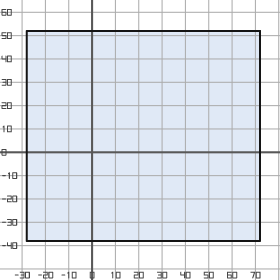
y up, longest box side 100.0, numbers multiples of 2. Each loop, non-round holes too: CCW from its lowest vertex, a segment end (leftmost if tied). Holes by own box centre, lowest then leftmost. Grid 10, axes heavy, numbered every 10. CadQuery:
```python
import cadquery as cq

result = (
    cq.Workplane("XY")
    .moveTo(-28.0, -38.0)
    .lineTo(72.0, -38.0)
    .lineTo(72.0, 52.0)
    .lineTo(-28.0, 52.0)
    .close()
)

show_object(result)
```